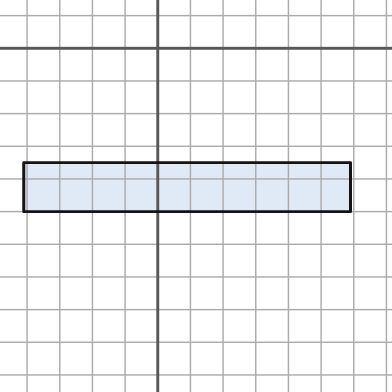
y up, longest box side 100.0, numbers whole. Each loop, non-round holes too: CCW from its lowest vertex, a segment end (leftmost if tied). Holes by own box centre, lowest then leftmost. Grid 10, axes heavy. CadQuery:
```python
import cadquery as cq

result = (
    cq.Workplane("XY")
    .moveTo(-41.0, -50.0)
    .lineTo(59.0, -50.0)
    .lineTo(59.0, -35.0)
    .lineTo(-41.0, -35.0)
    .close()
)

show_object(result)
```